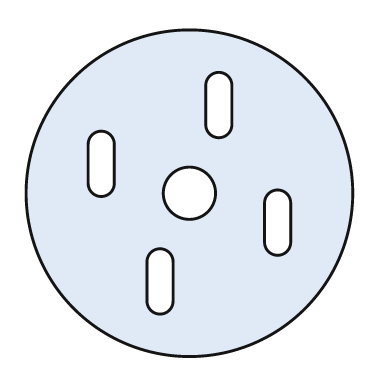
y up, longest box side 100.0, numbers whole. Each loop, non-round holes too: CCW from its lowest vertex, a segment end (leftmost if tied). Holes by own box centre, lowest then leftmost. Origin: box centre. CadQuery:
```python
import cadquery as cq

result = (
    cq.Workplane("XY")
    .moveTo(0.0, 0.0)
    .circle(50.0)
    .moveTo(-13.0, -33.0)
    .threePointArc((-9.0, -37.0), (-5.0, -33.0))
    .lineTo(-5.0, -21.0)
    .threePointArc((-9.0, -17.0), (-13.0, -21.0))
    .close()
    .moveTo(23.0, -15.0)
    .threePointArc((27.0, -19.0), (31.0, -15.0))
    .lineTo(31.0, -3.0)
    .threePointArc((27.0, 1.0), (23.0, -3.0))
    .close()
    .moveTo(0.0, 0.0)
    .circle(8.0)
    .moveTo(-31.0, 3.0)
    .threePointArc((-27.0, -1.0), (-23.0, 3.0))
    .lineTo(-23.0, 15.0)
    .threePointArc((-27.0, 19.0), (-31.0, 15.0))
    .close()
    .moveTo(5.0, 21.0)
    .threePointArc((9.0, 17.0), (13.0, 21.0))
    .lineTo(13.0, 33.0)
    .threePointArc((9.0, 37.0), (5.0, 33.0))
    .close()
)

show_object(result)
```